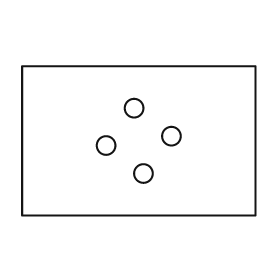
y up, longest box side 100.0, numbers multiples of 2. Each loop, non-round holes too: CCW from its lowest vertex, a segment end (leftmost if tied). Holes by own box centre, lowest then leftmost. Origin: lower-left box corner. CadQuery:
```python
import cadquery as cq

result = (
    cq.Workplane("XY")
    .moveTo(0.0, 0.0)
    .lineTo(100.0, 0.0)
    .lineTo(100.0, 64.0)
    .lineTo(0.0, 64.0)
    .close()
    .moveTo(52.0, 18.0)
    .circle(4.0)
    .moveTo(36.0, 30.0)
    .circle(4.0)
    .moveTo(64.0, 34.0)
    .circle(4.0)
    .moveTo(48.0, 46.0)
    .circle(4.0)
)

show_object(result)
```